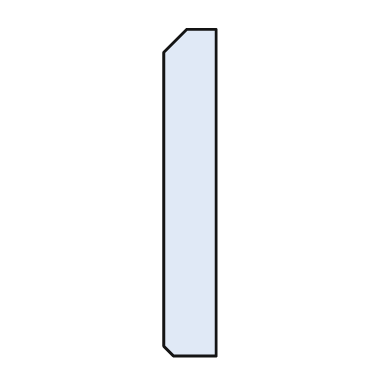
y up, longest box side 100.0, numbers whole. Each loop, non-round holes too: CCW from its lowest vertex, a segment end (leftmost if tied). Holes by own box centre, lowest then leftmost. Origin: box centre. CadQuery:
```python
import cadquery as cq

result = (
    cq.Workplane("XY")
    .moveTo(-5.0, -50.0)
    .lineTo(8.0, -50.0)
    .lineTo(8.0, 50.0)
    .lineTo(-1.0, 50.0)
    .lineTo(-8.0, 43.0)
    .lineTo(-8.0, -47.0)
    .close()
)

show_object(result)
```